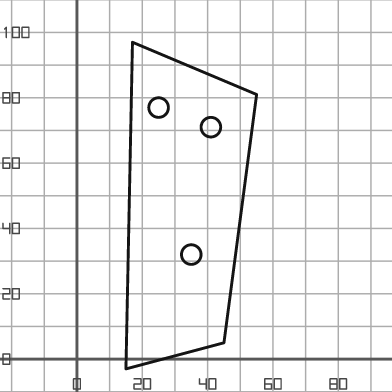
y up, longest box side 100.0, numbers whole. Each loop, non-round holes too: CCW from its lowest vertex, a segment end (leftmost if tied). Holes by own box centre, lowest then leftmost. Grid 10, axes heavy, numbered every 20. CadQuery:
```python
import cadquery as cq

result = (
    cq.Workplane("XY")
    .moveTo(15.0, -3.0)
    .lineTo(45.0, 5.0)
    .lineTo(55.0, 81.0)
    .lineTo(17.0, 97.0)
    .close()
    .moveTo(35.0, 32.0)
    .circle(3.0)
    .moveTo(41.0, 71.0)
    .circle(3.0)
    .moveTo(25.0, 77.0)
    .circle(3.0)
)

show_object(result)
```